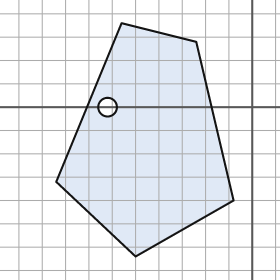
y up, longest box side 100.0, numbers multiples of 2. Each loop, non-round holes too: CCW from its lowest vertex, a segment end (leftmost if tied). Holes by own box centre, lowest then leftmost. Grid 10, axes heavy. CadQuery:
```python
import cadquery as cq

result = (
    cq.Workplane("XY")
    .moveTo(-50.0, -64.0)
    .lineTo(-8.0, -40.0)
    .lineTo(-24.0, 28.0)
    .lineTo(-56.0, 36.0)
    .lineTo(-84.0, -32.0)
    .close()
    .moveTo(-62.0, 0.0)
    .circle(4.0)
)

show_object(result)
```